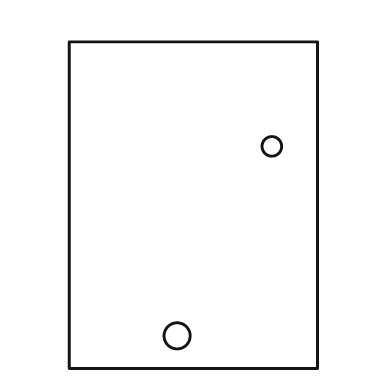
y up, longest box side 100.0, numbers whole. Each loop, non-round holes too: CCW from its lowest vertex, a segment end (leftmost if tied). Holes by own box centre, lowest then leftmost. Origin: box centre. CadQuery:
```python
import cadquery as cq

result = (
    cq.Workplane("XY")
    .moveTo(-38.0, -50.0)
    .lineTo(38.0, -50.0)
    .lineTo(38.0, 50.0)
    .lineTo(-38.0, 50.0)
    .close()
    .moveTo(-5.0, -40.0)
    .circle(4.0)
    .moveTo(24.0, 18.0)
    .circle(3.0)
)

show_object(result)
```